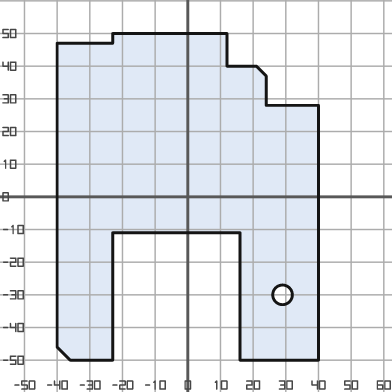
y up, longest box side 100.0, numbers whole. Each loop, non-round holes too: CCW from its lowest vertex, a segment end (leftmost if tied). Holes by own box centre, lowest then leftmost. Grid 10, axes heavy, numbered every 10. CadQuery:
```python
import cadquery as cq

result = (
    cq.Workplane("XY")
    .moveTo(-36.0, -50.0)
    .lineTo(-23.0, -50.0)
    .lineTo(-23.0, -11.0)
    .lineTo(16.0, -11.0)
    .lineTo(16.0, -50.0)
    .lineTo(40.0, -50.0)
    .lineTo(40.0, 28.0)
    .lineTo(24.0, 28.0)
    .lineTo(24.0, 37.0)
    .lineTo(21.0, 40.0)
    .lineTo(12.0, 40.0)
    .lineTo(12.0, 50.0)
    .lineTo(-23.0, 50.0)
    .lineTo(-23.0, 47.0)
    .lineTo(-40.0, 47.0)
    .lineTo(-40.0, -46.0)
    .close()
    .moveTo(29.0, -30.0)
    .circle(3.0)
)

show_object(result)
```